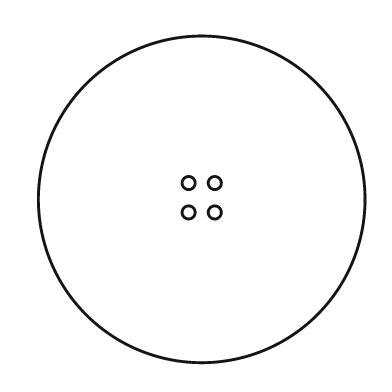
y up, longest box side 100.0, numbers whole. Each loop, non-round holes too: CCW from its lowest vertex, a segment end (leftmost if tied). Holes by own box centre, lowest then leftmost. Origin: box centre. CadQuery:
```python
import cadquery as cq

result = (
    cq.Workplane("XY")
    .moveTo(0.0, 0.0)
    .circle(50.0)
    .moveTo(-4.0, -4.0)
    .circle(2.0)
    .moveTo(4.0, -4.0)
    .circle(2.0)
    .moveTo(-4.0, 5.0)
    .circle(2.0)
    .moveTo(4.0, 5.0)
    .circle(2.0)
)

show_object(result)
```